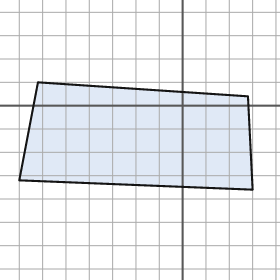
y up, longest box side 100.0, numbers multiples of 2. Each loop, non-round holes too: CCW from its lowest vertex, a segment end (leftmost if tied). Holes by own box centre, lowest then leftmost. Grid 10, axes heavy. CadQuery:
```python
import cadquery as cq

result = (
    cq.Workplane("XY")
    .moveTo(30.0, -36.0)
    .lineTo(28.0, 4.0)
    .lineTo(-62.0, 10.0)
    .lineTo(-70.0, -32.0)
    .close()
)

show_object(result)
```